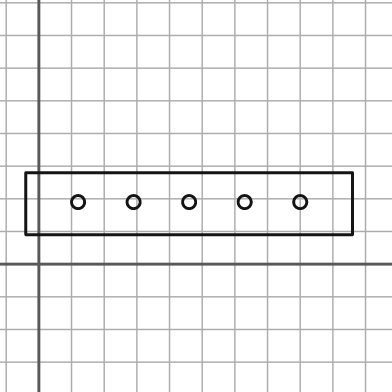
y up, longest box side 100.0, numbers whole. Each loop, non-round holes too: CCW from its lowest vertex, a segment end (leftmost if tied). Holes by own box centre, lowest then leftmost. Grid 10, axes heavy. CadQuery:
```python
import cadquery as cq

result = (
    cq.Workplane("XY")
    .moveTo(-4.0, 9.0)
    .lineTo(96.0, 9.0)
    .lineTo(96.0, 28.0)
    .lineTo(-4.0, 28.0)
    .close()
    .moveTo(12.0, 19.0)
    .circle(2.0)
    .moveTo(29.0, 19.0)
    .circle(2.0)
    .moveTo(46.0, 19.0)
    .circle(2.0)
    .moveTo(63.0, 19.0)
    .circle(2.0)
    .moveTo(80.0, 19.0)
    .circle(2.0)
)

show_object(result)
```